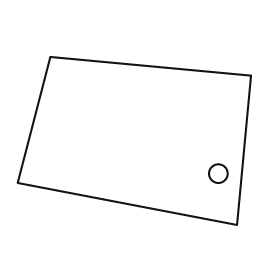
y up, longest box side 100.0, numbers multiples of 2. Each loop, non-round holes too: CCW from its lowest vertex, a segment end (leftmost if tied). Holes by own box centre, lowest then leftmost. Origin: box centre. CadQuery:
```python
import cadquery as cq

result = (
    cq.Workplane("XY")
    .moveTo(44.0, -36.0)
    .lineTo(50.0, 28.0)
    .lineTo(-36.0, 36.0)
    .lineTo(-50.0, -18.0)
    .close()
    .moveTo(36.0, -14.0)
    .circle(4.0)
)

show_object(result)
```